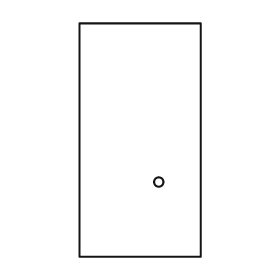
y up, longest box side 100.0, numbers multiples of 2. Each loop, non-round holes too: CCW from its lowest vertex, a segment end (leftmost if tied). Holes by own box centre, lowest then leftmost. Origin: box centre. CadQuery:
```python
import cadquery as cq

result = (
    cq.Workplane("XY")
    .moveTo(-26.0, -50.0)
    .lineTo(26.0, -50.0)
    .lineTo(26.0, 50.0)
    .lineTo(-26.0, 50.0)
    .close()
    .moveTo(8.0, -18.0)
    .circle(2.0)
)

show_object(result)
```